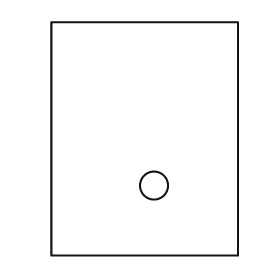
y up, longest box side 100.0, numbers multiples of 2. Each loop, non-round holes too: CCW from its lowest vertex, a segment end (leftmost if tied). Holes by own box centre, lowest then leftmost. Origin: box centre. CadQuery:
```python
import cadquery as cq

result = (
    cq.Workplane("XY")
    .moveTo(-40.0, -50.0)
    .lineTo(40.0, -50.0)
    .lineTo(40.0, 50.0)
    .lineTo(-40.0, 50.0)
    .close()
    .moveTo(4.0, -20.0)
    .circle(6.0)
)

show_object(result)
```